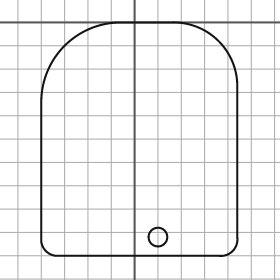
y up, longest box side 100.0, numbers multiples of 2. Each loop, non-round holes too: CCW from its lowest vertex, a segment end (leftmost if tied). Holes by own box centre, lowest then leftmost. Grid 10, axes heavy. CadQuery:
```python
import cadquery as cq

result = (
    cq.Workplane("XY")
    .moveTo(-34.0, -100.0)
    .lineTo(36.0, -100.0)
    .threePointArc((42.0, -98.0), (44.0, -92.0))
    .lineTo(44.0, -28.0)
    .threePointArc((36.0, -8.0), (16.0, 0.0))
    .lineTo(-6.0, 0.0)
    .threePointArc((-30.0, -10.0), (-40.0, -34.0))
    .lineTo(-40.0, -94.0)
    .threePointArc((-38.0, -98.0), (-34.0, -100.0))
    .close()
    .moveTo(10.0, -92.0)
    .circle(4.0)
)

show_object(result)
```